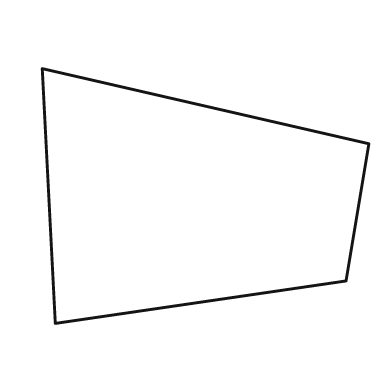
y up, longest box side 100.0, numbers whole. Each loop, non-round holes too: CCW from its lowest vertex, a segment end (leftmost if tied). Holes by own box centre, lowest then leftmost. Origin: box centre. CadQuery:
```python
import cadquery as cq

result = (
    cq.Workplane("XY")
    .moveTo(-46.0, -39.0)
    .lineTo(43.0, -26.0)
    .lineTo(50.0, 16.0)
    .lineTo(-50.0, 39.0)
    .close()
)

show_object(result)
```